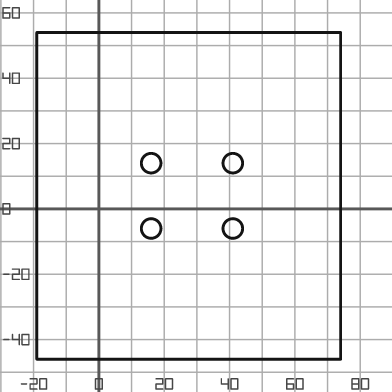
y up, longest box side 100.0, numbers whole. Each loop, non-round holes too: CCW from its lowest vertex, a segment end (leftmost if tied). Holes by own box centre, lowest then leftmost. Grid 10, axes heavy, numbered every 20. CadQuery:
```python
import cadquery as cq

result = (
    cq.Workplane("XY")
    .moveTo(-19.0, -46.0)
    .lineTo(74.0, -46.0)
    .lineTo(74.0, 54.0)
    .lineTo(-19.0, 54.0)
    .close()
    .moveTo(16.0, -6.0)
    .circle(3.0)
    .moveTo(41.0, -6.0)
    .circle(3.0)
    .moveTo(16.0, 14.0)
    .circle(3.0)
    .moveTo(41.0, 14.0)
    .circle(3.0)
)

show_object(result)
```